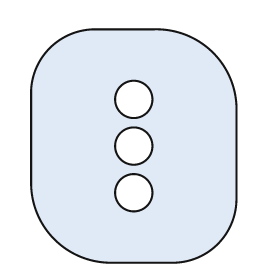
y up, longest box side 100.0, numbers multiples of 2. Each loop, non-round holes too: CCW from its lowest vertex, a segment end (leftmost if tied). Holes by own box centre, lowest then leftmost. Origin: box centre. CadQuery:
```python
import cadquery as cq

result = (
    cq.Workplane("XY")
    .moveTo(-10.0, -50.0)
    .lineTo(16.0, -50.0)
    .threePointArc((36.0, -42.0), (44.0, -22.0))
    .lineTo(44.0, 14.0)
    .threePointArc((34.0, 40.0), (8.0, 50.0))
    .lineTo(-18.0, 50.0)
    .threePointArc((-36.0, 42.0), (-44.0, 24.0))
    .lineTo(-44.0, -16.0)
    .threePointArc((-34.0, -40.0), (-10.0, -50.0))
    .close()
    .moveTo(0.0, -20.0)
    .circle(8.0)
    .moveTo(0.0, 0.0)
    .circle(8.0)
    .moveTo(0.0, 20.0)
    .circle(8.0)
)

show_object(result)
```